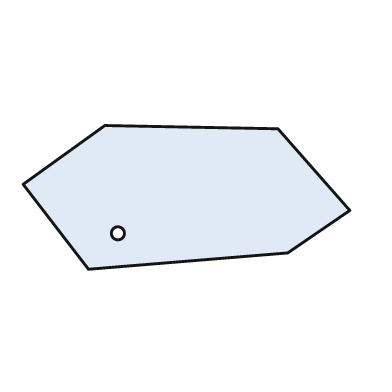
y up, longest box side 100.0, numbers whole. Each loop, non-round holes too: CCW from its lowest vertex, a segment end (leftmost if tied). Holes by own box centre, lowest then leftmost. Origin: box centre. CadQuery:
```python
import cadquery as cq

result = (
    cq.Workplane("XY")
    .moveTo(-30.0, -22.0)
    .lineTo(31.0, -17.0)
    .lineTo(50.0, -4.0)
    .lineTo(28.0, 21.0)
    .lineTo(-25.0, 22.0)
    .lineTo(-50.0, 4.0)
    .close()
    .moveTo(-21.0, -11.0)
    .circle(2.0)
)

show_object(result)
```